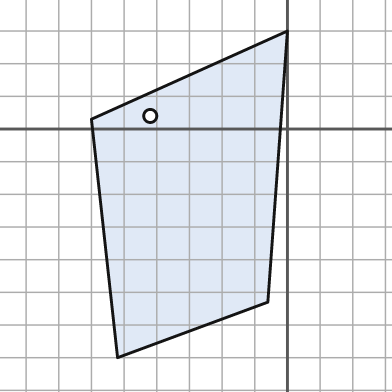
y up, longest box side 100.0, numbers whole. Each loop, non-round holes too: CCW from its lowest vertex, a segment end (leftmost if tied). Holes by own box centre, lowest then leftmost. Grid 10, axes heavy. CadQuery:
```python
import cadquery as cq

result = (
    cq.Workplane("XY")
    .moveTo(-52.0, -70.0)
    .lineTo(-6.0, -53.0)
    .lineTo(0.0, 30.0)
    .lineTo(-60.0, 3.0)
    .close()
    .moveTo(-42.0, 4.0)
    .circle(2.0)
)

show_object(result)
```